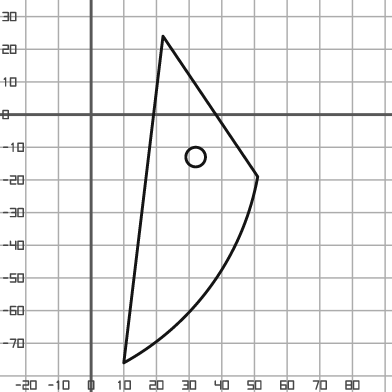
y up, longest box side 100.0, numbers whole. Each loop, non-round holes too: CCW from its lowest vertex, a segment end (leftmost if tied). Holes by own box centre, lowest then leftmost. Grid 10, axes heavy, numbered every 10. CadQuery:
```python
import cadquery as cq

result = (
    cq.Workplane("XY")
    .moveTo(10.0, -76.0)
    .threePointArc((37.0, -52.0), (51.0, -19.0))
    .lineTo(22.0, 24.0)
    .close()
    .moveTo(32.0, -13.0)
    .circle(3.0)
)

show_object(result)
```